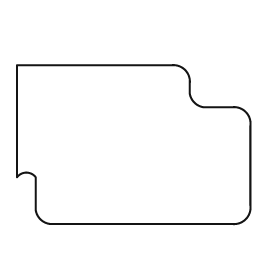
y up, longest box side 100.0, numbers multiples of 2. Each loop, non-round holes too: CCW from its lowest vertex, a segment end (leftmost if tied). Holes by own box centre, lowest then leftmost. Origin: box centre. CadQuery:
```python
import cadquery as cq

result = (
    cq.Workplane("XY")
    .moveTo(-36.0, -34.0)
    .lineTo(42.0, -34.0)
    .threePointArc((48.0, -32.0), (50.0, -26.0))
    .lineTo(50.0, 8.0)
    .threePointArc((48.0, 14.0), (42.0, 16.0))
    .lineTo(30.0, 16.0)
    .threePointArc((26.0, 18.0), (24.0, 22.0))
    .lineTo(24.0, 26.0)
    .threePointArc((22.0, 32.0), (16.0, 34.0))
    .lineTo(-50.0, 34.0)
    .lineTo(-50.0, -14.0)
    .threePointArc((-46.0, -12.0), (-42.0, -14.0))
    .lineTo(-42.0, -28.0)
    .threePointArc((-40.0, -32.0), (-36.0, -34.0))
    .close()
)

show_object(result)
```